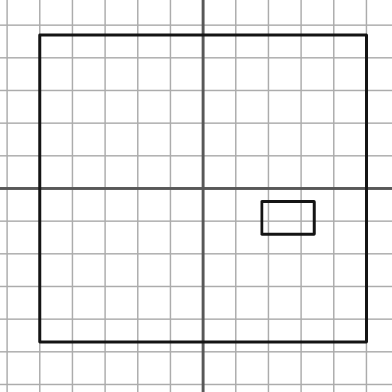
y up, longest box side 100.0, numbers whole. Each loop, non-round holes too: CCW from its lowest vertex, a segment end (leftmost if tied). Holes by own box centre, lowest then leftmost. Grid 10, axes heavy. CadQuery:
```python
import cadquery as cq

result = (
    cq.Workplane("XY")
    .moveTo(-50.0, -47.0)
    .lineTo(50.0, -47.0)
    .lineTo(50.0, 47.0)
    .lineTo(-50.0, 47.0)
    .close()
    .moveTo(18.0, -14.0)
    .lineTo(34.0, -14.0)
    .lineTo(34.0, -4.0)
    .lineTo(18.0, -4.0)
    .close()
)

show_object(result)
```